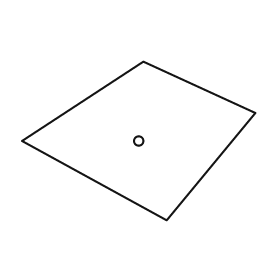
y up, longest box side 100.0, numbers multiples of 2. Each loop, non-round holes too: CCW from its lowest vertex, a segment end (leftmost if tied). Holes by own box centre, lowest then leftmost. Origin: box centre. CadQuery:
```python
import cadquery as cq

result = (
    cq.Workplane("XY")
    .moveTo(12.0, -34.0)
    .lineTo(50.0, 12.0)
    .lineTo(2.0, 34.0)
    .lineTo(-50.0, 0.0)
    .close()
    .moveTo(0.0, 0.0)
    .circle(2.0)
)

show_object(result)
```